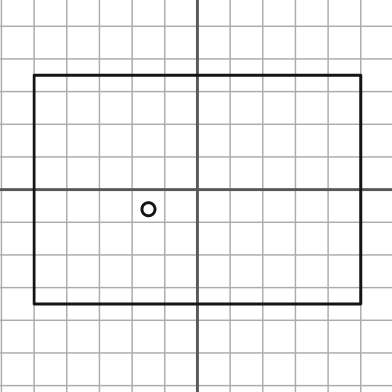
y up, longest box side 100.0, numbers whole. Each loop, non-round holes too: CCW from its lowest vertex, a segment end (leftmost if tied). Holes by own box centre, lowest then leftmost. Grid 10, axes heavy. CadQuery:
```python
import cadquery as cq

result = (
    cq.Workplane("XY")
    .moveTo(-50.0, -35.0)
    .lineTo(50.0, -35.0)
    .lineTo(50.0, 35.0)
    .lineTo(-50.0, 35.0)
    .close()
    .moveTo(-15.0, -6.0)
    .circle(2.0)
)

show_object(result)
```